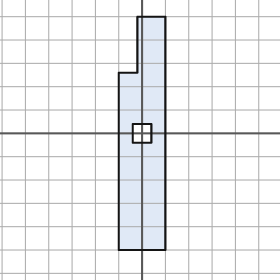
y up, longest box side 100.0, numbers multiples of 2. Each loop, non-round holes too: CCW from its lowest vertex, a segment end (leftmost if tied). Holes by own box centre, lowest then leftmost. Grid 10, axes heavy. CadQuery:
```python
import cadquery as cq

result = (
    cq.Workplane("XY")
    .moveTo(-10.0, -50.0)
    .lineTo(10.0, -50.0)
    .lineTo(10.0, 50.0)
    .lineTo(-2.0, 50.0)
    .lineTo(-2.0, 26.0)
    .lineTo(-10.0, 26.0)
    .close()
    .moveTo(-4.0, -4.0)
    .lineTo(4.0, -4.0)
    .lineTo(4.0, 4.0)
    .lineTo(-4.0, 4.0)
    .close()
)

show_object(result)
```